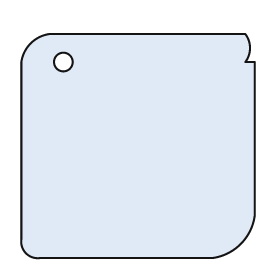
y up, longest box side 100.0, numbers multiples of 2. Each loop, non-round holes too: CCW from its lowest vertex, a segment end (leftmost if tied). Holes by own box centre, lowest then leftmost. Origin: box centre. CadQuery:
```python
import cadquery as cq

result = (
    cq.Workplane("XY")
    .moveTo(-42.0, -48.0)
    .lineTo(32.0, -48.0)
    .threePointArc((44.0, -42.0), (50.0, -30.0))
    .lineTo(50.0, 36.0)
    .lineTo(46.0, 36.0)
    .threePointArc((48.0, 42.0), (46.0, 48.0))
    .lineTo(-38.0, 48.0)
    .threePointArc((-46.0, 44.0), (-50.0, 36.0))
    .lineTo(-50.0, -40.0)
    .threePointArc((-48.0, -46.0), (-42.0, -48.0))
    .close()
    .moveTo(-32.0, 36.0)
    .circle(4.0)
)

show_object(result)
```